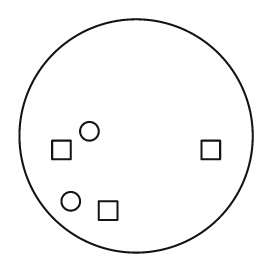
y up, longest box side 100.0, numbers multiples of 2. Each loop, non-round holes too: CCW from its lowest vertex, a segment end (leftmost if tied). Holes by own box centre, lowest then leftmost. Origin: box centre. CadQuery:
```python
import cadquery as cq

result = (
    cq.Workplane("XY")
    .moveTo(0.0, 0.0)
    .circle(50.0)
    .moveTo(-16.0, -36.0)
    .lineTo(-8.0, -36.0)
    .lineTo(-8.0, -28.0)
    .lineTo(-16.0, -28.0)
    .close()
    .moveTo(-28.0, -28.0)
    .circle(4.0)
    .moveTo(-36.0, -10.0)
    .lineTo(-28.0, -10.0)
    .lineTo(-28.0, -2.0)
    .lineTo(-36.0, -2.0)
    .close()
    .moveTo(28.0, -10.0)
    .lineTo(36.0, -10.0)
    .lineTo(36.0, -2.0)
    .lineTo(28.0, -2.0)
    .close()
    .moveTo(-20.0, 2.0)
    .circle(4.0)
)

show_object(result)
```